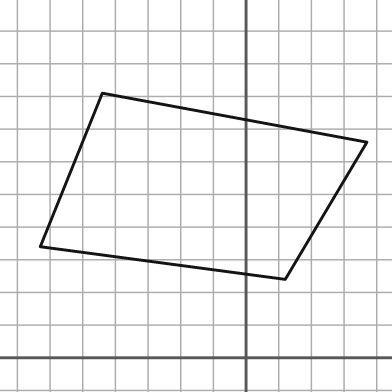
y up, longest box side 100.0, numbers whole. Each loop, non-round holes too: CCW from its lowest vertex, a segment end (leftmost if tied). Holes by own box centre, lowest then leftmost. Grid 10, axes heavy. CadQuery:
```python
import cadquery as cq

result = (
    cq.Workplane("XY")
    .moveTo(12.0, 24.0)
    .lineTo(37.0, 66.0)
    .lineTo(-44.0, 81.0)
    .lineTo(-63.0, 34.0)
    .close()
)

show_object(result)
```